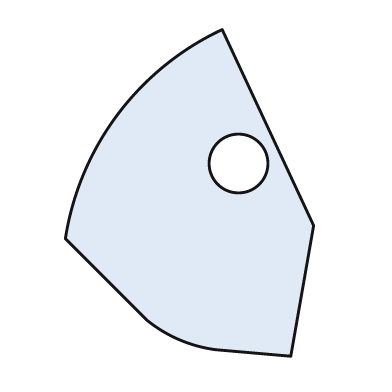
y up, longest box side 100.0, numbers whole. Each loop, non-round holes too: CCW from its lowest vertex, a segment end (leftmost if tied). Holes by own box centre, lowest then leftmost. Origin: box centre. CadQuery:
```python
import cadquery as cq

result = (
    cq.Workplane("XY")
    .moveTo(31.0, -50.0)
    .lineTo(38.0, -10.0)
    .lineTo(10.0, 50.0)
    .threePointArc((-22.0, 24.0), (-38.0, -14.0))
    .lineTo(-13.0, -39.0)
    .threePointArc((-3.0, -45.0), (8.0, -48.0))
    .close()
    .moveTo(15.0, 9.0)
    .circle(9.0)
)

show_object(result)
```